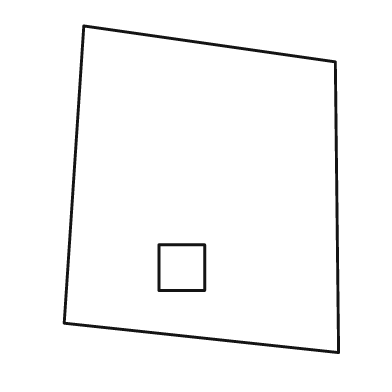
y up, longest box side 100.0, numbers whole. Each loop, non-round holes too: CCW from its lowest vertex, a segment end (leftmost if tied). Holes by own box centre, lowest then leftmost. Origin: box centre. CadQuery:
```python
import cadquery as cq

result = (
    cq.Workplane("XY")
    .moveTo(42.0, -50.0)
    .lineTo(41.0, 39.0)
    .lineTo(-36.0, 50.0)
    .lineTo(-42.0, -41.0)
    .close()
    .moveTo(-13.0, -31.0)
    .lineTo(1.0, -31.0)
    .lineTo(1.0, -17.0)
    .lineTo(-13.0, -17.0)
    .close()
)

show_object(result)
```